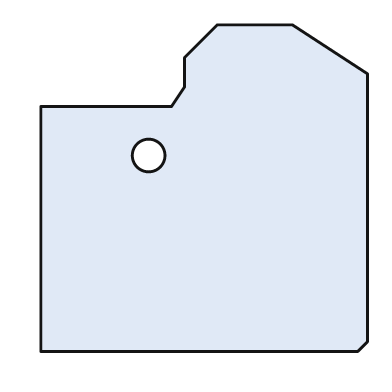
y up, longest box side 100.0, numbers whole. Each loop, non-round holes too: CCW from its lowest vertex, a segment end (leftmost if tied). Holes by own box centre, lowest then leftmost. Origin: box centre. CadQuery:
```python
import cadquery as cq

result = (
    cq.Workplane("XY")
    .moveTo(-50.0, -50.0)
    .lineTo(47.0, -50.0)
    .lineTo(50.0, -47.0)
    .lineTo(50.0, 35.0)
    .lineTo(27.0, 50.0)
    .lineTo(4.0, 50.0)
    .lineTo(-6.0, 40.0)
    .lineTo(-6.0, 31.0)
    .lineTo(-10.0, 25.0)
    .lineTo(-50.0, 25.0)
    .close()
    .moveTo(-17.0, 10.0)
    .circle(5.0)
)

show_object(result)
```